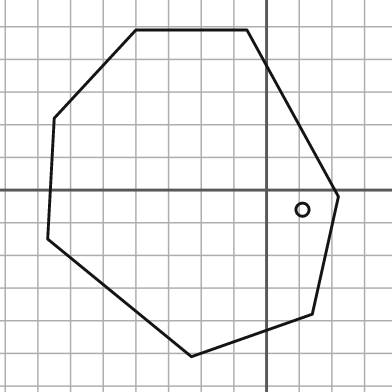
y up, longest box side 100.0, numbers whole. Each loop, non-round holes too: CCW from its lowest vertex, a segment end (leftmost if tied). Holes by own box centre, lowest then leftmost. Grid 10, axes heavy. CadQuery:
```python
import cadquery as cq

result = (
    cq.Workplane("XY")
    .moveTo(-23.0, -51.0)
    .lineTo(14.0, -38.0)
    .lineTo(22.0, -2.0)
    .lineTo(-6.0, 49.0)
    .lineTo(-40.0, 49.0)
    .lineTo(-65.0, 22.0)
    .lineTo(-67.0, -15.0)
    .close()
    .moveTo(11.0, -6.0)
    .circle(2.0)
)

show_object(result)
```